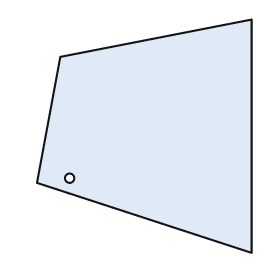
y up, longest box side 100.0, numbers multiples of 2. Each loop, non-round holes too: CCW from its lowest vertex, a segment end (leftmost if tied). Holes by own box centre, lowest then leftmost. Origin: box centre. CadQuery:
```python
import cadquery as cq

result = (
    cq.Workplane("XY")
    .moveTo(46.0, -50.0)
    .lineTo(46.0, 50.0)
    .lineTo(-36.0, 34.0)
    .lineTo(-46.0, -20.0)
    .close()
    .moveTo(-32.0, -18.0)
    .circle(2.0)
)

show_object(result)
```